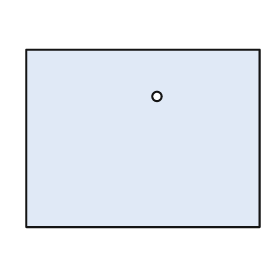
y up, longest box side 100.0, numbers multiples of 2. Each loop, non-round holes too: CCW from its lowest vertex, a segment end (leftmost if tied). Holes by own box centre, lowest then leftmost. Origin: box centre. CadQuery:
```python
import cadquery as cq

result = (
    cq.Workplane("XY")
    .moveTo(-50.0, -38.0)
    .lineTo(50.0, -38.0)
    .lineTo(50.0, 38.0)
    .lineTo(-50.0, 38.0)
    .close()
    .moveTo(6.0, 18.0)
    .circle(2.0)
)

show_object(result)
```